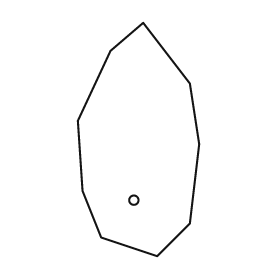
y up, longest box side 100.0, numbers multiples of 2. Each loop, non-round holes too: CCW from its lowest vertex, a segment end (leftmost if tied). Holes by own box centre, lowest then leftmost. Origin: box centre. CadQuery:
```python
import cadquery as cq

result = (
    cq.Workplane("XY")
    .moveTo(8.0, -50.0)
    .lineTo(22.0, -36.0)
    .lineTo(26.0, -2.0)
    .lineTo(22.0, 24.0)
    .lineTo(2.0, 50.0)
    .lineTo(-12.0, 38.0)
    .lineTo(-26.0, 8.0)
    .lineTo(-24.0, -22.0)
    .lineTo(-16.0, -42.0)
    .close()
    .moveTo(-2.0, -26.0)
    .circle(2.0)
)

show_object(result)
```